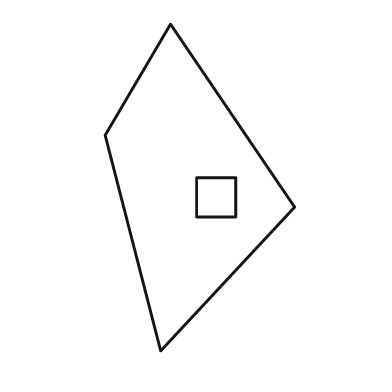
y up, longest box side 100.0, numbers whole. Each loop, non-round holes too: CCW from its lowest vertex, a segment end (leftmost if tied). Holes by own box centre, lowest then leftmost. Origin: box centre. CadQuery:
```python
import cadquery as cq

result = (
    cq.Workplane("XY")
    .moveTo(-12.0, -50.0)
    .lineTo(29.0, -6.0)
    .lineTo(-9.0, 50.0)
    .lineTo(-29.0, 16.0)
    .close()
    .moveTo(-1.0, -9.0)
    .lineTo(11.0, -9.0)
    .lineTo(11.0, 3.0)
    .lineTo(-1.0, 3.0)
    .close()
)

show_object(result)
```